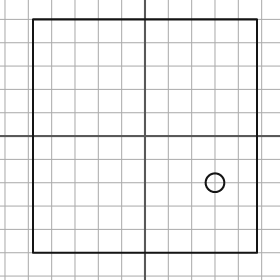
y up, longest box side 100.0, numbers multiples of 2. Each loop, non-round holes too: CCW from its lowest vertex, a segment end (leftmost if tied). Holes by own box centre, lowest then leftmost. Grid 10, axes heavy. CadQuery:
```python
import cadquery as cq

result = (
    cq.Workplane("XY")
    .moveTo(-48.0, -50.0)
    .lineTo(48.0, -50.0)
    .lineTo(48.0, 50.0)
    .lineTo(-48.0, 50.0)
    .close()
    .moveTo(30.0, -20.0)
    .circle(4.0)
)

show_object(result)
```